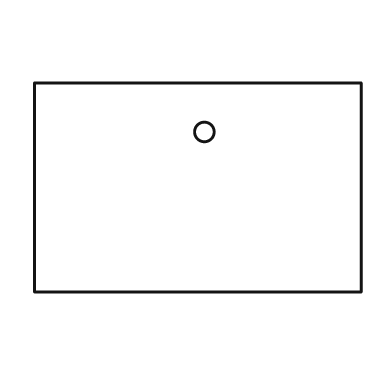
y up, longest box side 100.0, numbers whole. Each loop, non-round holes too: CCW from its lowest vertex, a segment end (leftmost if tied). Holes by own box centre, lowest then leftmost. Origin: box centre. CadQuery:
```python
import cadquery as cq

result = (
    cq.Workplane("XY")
    .moveTo(-50.0, -32.0)
    .lineTo(50.0, -32.0)
    .lineTo(50.0, 32.0)
    .lineTo(-50.0, 32.0)
    .close()
    .moveTo(2.0, 17.0)
    .circle(3.0)
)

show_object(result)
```